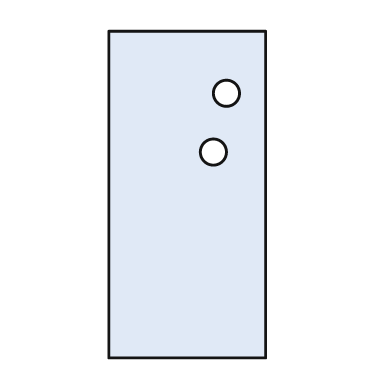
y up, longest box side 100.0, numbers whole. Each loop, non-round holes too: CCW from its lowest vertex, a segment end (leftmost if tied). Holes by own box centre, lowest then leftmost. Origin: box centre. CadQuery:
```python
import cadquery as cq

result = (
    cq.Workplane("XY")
    .moveTo(-24.0, -50.0)
    .lineTo(24.0, -50.0)
    .lineTo(24.0, 50.0)
    .lineTo(-24.0, 50.0)
    .close()
    .moveTo(8.0, 13.0)
    .circle(4.0)
    .moveTo(12.0, 31.0)
    .circle(4.0)
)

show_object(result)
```